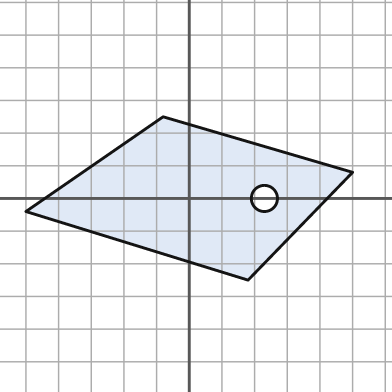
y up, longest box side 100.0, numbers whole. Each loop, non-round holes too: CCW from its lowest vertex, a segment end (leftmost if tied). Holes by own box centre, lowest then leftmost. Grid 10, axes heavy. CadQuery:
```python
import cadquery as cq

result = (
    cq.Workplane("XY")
    .moveTo(18.0, -25.0)
    .lineTo(50.0, 8.0)
    .lineTo(-8.0, 25.0)
    .lineTo(-50.0, -4.0)
    .close()
    .moveTo(23.0, 0.0)
    .circle(4.0)
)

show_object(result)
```